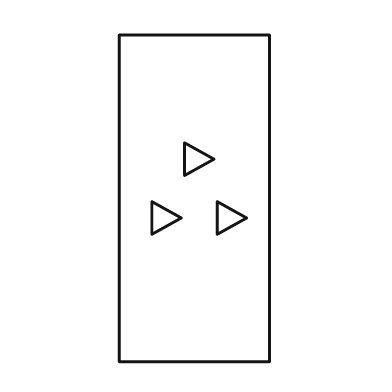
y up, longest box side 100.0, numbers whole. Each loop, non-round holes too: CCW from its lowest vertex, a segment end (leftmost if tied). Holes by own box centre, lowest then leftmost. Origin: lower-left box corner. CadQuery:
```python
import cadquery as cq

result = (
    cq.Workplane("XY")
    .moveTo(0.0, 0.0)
    .lineTo(46.0, 0.0)
    .lineTo(46.0, 100.0)
    .lineTo(0.0, 100.0)
    .close()
    .moveTo(10.0, 39.0)
    .lineTo(19.0, 44.0)
    .lineTo(10.0, 49.0)
    .close()
    .moveTo(30.0, 39.0)
    .lineTo(39.0, 44.0)
    .lineTo(30.0, 49.0)
    .close()
    .moveTo(20.0, 57.0)
    .lineTo(29.0, 62.0)
    .lineTo(20.0, 67.0)
    .close()
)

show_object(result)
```